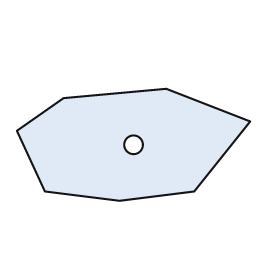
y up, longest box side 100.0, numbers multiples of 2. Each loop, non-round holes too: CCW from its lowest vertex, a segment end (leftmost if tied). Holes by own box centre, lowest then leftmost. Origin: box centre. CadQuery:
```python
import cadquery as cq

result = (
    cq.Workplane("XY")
    .moveTo(-6.0, -24.0)
    .lineTo(26.0, -20.0)
    .lineTo(50.0, 10.0)
    .lineTo(14.0, 24.0)
    .lineTo(-30.0, 20.0)
    .lineTo(-50.0, 6.0)
    .lineTo(-38.0, -20.0)
    .close()
    .moveTo(0.0, 0.0)
    .circle(4.0)
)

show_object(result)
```